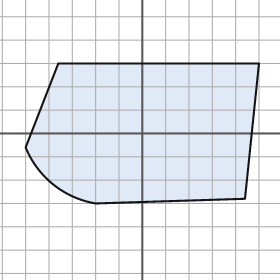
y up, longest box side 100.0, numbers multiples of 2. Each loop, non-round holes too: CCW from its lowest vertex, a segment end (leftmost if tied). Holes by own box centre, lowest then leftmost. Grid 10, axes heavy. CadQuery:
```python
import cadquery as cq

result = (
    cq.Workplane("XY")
    .moveTo(-20.0, -30.0)
    .lineTo(44.0, -28.0)
    .lineTo(50.0, 30.0)
    .lineTo(-36.0, 30.0)
    .lineTo(-50.0, -6.0)
    .threePointArc((-38.0, -22.0), (-20.0, -30.0))
    .close()
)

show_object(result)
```